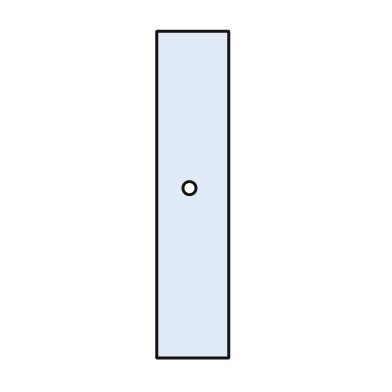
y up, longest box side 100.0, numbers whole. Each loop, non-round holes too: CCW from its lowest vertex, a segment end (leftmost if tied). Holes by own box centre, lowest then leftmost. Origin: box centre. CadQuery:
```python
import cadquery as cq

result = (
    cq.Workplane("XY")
    .moveTo(-11.0, -50.0)
    .lineTo(11.0, -50.0)
    .lineTo(11.0, 50.0)
    .lineTo(-11.0, 50.0)
    .close()
    .moveTo(-1.0, 2.0)
    .circle(2.0)
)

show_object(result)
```